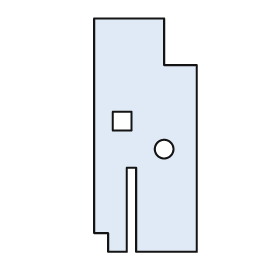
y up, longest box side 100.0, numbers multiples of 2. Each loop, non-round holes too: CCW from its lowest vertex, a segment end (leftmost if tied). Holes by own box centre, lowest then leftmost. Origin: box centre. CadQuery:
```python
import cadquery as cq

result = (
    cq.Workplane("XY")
    .moveTo(-16.0, -50.0)
    .lineTo(-8.0, -50.0)
    .lineTo(-8.0, -14.0)
    .lineTo(-4.0, -14.0)
    .lineTo(-4.0, -50.0)
    .lineTo(22.0, -50.0)
    .lineTo(22.0, 30.0)
    .lineTo(8.0, 30.0)
    .lineTo(8.0, 50.0)
    .lineTo(-22.0, 50.0)
    .lineTo(-22.0, -42.0)
    .lineTo(-16.0, -42.0)
    .close()
    .moveTo(8.0, -6.0)
    .circle(4.0)
    .moveTo(-14.0, 2.0)
    .lineTo(-6.0, 2.0)
    .lineTo(-6.0, 10.0)
    .lineTo(-14.0, 10.0)
    .close()
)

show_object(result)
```